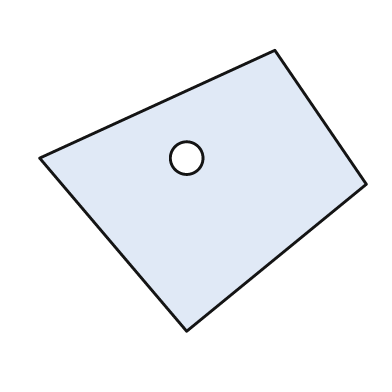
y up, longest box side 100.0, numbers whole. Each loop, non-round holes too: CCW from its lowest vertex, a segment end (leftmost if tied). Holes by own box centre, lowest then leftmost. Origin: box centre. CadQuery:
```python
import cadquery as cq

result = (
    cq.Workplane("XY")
    .moveTo(-5.0, -43.0)
    .lineTo(50.0, 2.0)
    .lineTo(22.0, 43.0)
    .lineTo(-50.0, 10.0)
    .close()
    .moveTo(-5.0, 10.0)
    .circle(5.0)
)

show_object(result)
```